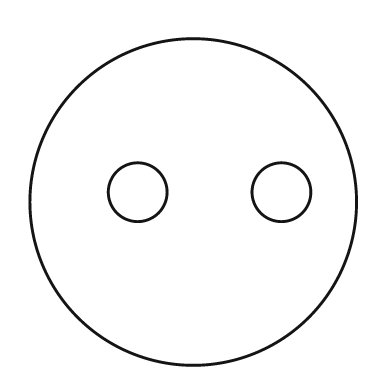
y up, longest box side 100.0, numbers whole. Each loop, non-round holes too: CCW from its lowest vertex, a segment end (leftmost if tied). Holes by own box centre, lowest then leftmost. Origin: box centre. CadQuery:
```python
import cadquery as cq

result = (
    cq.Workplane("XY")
    .moveTo(0.0, 0.0)
    .circle(50.0)
    .moveTo(-17.0, 3.0)
    .circle(9.0)
    .moveTo(27.0, 3.0)
    .circle(9.0)
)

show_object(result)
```